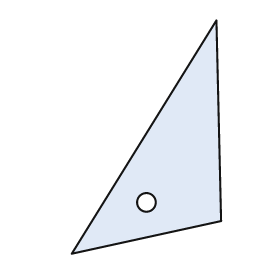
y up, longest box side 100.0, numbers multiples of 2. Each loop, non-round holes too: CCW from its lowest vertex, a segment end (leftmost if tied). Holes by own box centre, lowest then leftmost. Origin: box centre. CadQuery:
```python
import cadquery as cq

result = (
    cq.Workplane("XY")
    .moveTo(-32.0, -50.0)
    .lineTo(32.0, -36.0)
    .lineTo(30.0, 50.0)
    .close()
    .moveTo(0.0, -28.0)
    .circle(4.0)
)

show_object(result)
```